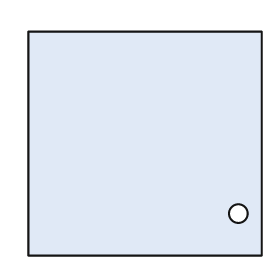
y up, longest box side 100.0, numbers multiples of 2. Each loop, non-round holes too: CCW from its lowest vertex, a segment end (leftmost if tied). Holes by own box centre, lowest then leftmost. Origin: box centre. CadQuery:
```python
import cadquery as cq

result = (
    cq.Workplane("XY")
    .moveTo(-50.0, -48.0)
    .lineTo(50.0, -48.0)
    .lineTo(50.0, 48.0)
    .lineTo(-50.0, 48.0)
    .close()
    .moveTo(40.0, -30.0)
    .circle(4.0)
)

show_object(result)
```